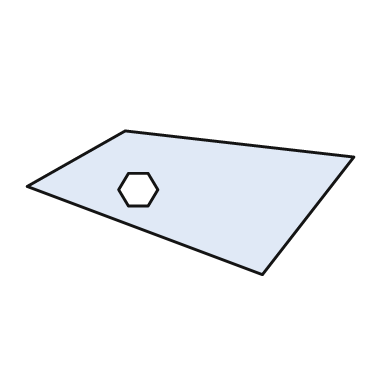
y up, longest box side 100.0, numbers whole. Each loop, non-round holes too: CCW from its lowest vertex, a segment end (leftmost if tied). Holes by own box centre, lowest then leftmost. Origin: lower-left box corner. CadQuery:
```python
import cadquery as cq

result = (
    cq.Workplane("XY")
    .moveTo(72.0, 0.0)
    .lineTo(100.0, 36.0)
    .lineTo(30.0, 44.0)
    .lineTo(0.0, 27.0)
    .close()
    .moveTo(31.0, 21.0)
    .lineTo(37.0, 21.0)
    .lineTo(40.0, 26.0)
    .lineTo(37.0, 31.0)
    .lineTo(31.0, 31.0)
    .lineTo(28.0, 26.0)
    .close()
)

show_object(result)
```